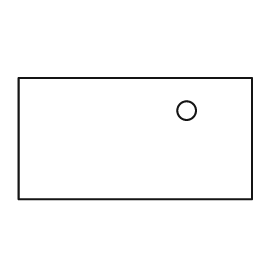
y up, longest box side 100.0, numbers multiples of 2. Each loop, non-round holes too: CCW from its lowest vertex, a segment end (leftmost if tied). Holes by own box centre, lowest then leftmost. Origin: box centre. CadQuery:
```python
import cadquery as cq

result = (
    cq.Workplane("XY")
    .moveTo(-50.0, -26.0)
    .lineTo(50.0, -26.0)
    .lineTo(50.0, 26.0)
    .lineTo(-50.0, 26.0)
    .close()
    .moveTo(22.0, 12.0)
    .circle(4.0)
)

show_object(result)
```